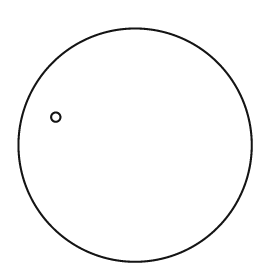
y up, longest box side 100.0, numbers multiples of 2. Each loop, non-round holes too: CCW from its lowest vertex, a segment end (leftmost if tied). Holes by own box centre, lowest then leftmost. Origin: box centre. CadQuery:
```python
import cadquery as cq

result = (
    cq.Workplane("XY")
    .moveTo(0.0, 0.0)
    .circle(50.0)
    .moveTo(-34.0, 12.0)
    .circle(2.0)
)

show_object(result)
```